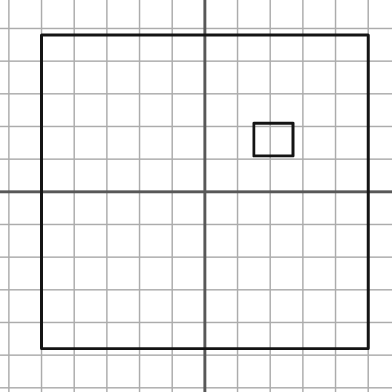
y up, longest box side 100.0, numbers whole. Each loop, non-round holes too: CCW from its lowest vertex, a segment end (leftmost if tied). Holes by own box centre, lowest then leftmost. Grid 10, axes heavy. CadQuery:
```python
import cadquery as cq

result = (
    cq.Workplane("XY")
    .moveTo(-50.0, -48.0)
    .lineTo(50.0, -48.0)
    .lineTo(50.0, 48.0)
    .lineTo(-50.0, 48.0)
    .close()
    .moveTo(15.0, 11.0)
    .lineTo(27.0, 11.0)
    .lineTo(27.0, 21.0)
    .lineTo(15.0, 21.0)
    .close()
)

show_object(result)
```